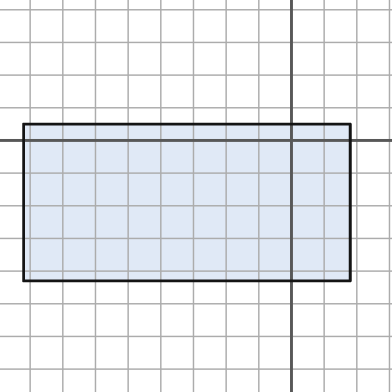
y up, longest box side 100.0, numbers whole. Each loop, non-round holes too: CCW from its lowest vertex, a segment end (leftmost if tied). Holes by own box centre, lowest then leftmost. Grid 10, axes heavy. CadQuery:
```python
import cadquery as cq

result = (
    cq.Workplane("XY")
    .moveTo(-82.0, -43.0)
    .lineTo(18.0, -43.0)
    .lineTo(18.0, 5.0)
    .lineTo(-82.0, 5.0)
    .close()
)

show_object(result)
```